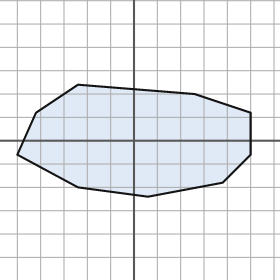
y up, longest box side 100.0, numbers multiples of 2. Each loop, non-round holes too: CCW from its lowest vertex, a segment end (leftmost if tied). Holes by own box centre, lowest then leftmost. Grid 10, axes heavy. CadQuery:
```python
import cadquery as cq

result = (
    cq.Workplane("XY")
    .moveTo(6.0, -24.0)
    .lineTo(38.0, -18.0)
    .lineTo(50.0, -6.0)
    .lineTo(50.0, 12.0)
    .lineTo(26.0, 20.0)
    .lineTo(-24.0, 24.0)
    .lineTo(-42.0, 12.0)
    .lineTo(-50.0, -6.0)
    .lineTo(-24.0, -20.0)
    .close()
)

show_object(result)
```